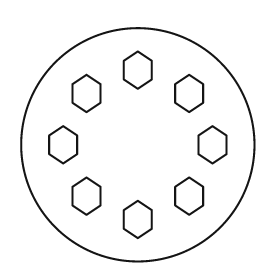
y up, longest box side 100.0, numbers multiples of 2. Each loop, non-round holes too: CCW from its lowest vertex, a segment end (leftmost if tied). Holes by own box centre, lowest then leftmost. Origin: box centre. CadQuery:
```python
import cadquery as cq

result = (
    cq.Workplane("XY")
    .moveTo(0.0, 0.0)
    .circle(50.0)
    .moveTo(0.0, -40.0)
    .lineTo(6.0, -36.0)
    .lineTo(6.0, -28.0)
    .lineTo(0.0, -24.0)
    .lineTo(-6.0, -28.0)
    .lineTo(-6.0, -36.0)
    .close()
    .moveTo(-22.0, -30.0)
    .lineTo(-16.0, -26.0)
    .lineTo(-16.0, -18.0)
    .lineTo(-22.0, -14.0)
    .lineTo(-28.0, -18.0)
    .lineTo(-28.0, -26.0)
    .close()
    .moveTo(22.0, -30.0)
    .lineTo(28.0, -26.0)
    .lineTo(28.0, -18.0)
    .lineTo(22.0, -14.0)
    .lineTo(16.0, -18.0)
    .lineTo(16.0, -26.0)
    .close()
    .moveTo(-32.0, -8.0)
    .lineTo(-26.0, -4.0)
    .lineTo(-26.0, 4.0)
    .lineTo(-32.0, 8.0)
    .lineTo(-38.0, 4.0)
    .lineTo(-38.0, -4.0)
    .close()
    .moveTo(32.0, -8.0)
    .lineTo(38.0, -4.0)
    .lineTo(38.0, 4.0)
    .lineTo(32.0, 8.0)
    .lineTo(26.0, 4.0)
    .lineTo(26.0, -4.0)
    .close()
    .moveTo(-22.0, 14.0)
    .lineTo(-16.0, 18.0)
    .lineTo(-16.0, 26.0)
    .lineTo(-22.0, 30.0)
    .lineTo(-28.0, 26.0)
    .lineTo(-28.0, 18.0)
    .close()
    .moveTo(22.0, 14.0)
    .lineTo(28.0, 18.0)
    .lineTo(28.0, 26.0)
    .lineTo(22.0, 30.0)
    .lineTo(16.0, 26.0)
    .lineTo(16.0, 18.0)
    .close()
    .moveTo(0.0, 24.0)
    .lineTo(6.0, 28.0)
    .lineTo(6.0, 36.0)
    .lineTo(0.0, 40.0)
    .lineTo(-6.0, 36.0)
    .lineTo(-6.0, 28.0)
    .close()
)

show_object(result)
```